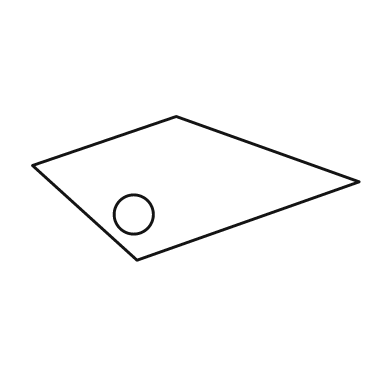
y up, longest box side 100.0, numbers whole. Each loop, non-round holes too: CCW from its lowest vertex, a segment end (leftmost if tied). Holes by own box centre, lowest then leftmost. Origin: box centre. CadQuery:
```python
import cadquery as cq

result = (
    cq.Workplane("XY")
    .moveTo(-18.0, -22.0)
    .lineTo(50.0, 2.0)
    .lineTo(-6.0, 22.0)
    .lineTo(-50.0, 7.0)
    .close()
    .moveTo(-19.0, -8.0)
    .circle(6.0)
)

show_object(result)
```